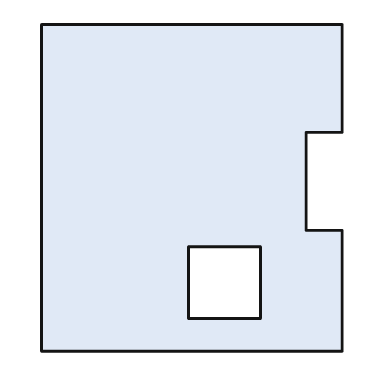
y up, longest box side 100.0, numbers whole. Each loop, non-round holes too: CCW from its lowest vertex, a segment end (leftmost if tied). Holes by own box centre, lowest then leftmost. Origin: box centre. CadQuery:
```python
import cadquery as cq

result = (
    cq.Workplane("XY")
    .moveTo(-46.0, -50.0)
    .lineTo(46.0, -50.0)
    .lineTo(46.0, -13.0)
    .lineTo(35.0, -13.0)
    .lineTo(35.0, 17.0)
    .lineTo(46.0, 17.0)
    .lineTo(46.0, 50.0)
    .lineTo(-46.0, 50.0)
    .close()
    .moveTo(-1.0, -40.0)
    .lineTo(21.0, -40.0)
    .lineTo(21.0, -18.0)
    .lineTo(-1.0, -18.0)
    .close()
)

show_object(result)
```